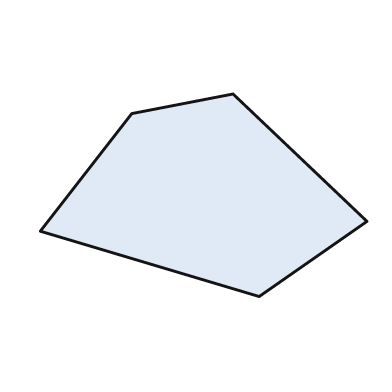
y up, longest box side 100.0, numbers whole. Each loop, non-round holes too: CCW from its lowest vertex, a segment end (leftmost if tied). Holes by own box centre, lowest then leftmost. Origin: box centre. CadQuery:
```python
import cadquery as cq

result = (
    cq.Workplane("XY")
    .moveTo(17.0, -31.0)
    .lineTo(50.0, -8.0)
    .lineTo(9.0, 31.0)
    .lineTo(-22.0, 25.0)
    .lineTo(-50.0, -11.0)
    .close()
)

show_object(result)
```